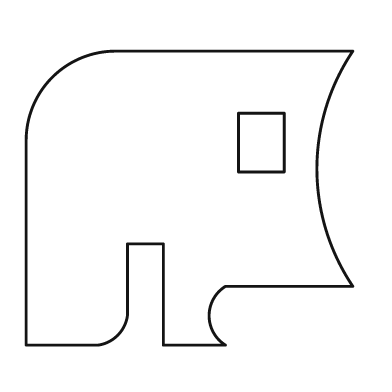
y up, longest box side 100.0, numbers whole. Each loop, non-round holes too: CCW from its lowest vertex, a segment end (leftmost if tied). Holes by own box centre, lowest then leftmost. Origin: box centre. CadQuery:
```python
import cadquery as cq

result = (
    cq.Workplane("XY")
    .moveTo(-50.0, -45.0)
    .lineTo(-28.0, -45.0)
    .threePointArc((-22.0, -42.0), (-19.0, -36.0))
    .lineTo(-19.0, -14.0)
    .lineTo(-8.0, -14.0)
    .lineTo(-8.0, -45.0)
    .lineTo(11.0, -45.0)
    .threePointArc((6.0, -36.0), (11.0, -27.0))
    .lineTo(50.0, -27.0)
    .threePointArc((39.0, 9.0), (50.0, 45.0))
    .lineTo(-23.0, 45.0)
    .threePointArc((-42.0, 37.0), (-50.0, 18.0))
    .close()
    .moveTo(15.0, 8.0)
    .lineTo(29.0, 8.0)
    .lineTo(29.0, 26.0)
    .lineTo(15.0, 26.0)
    .close()
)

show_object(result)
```